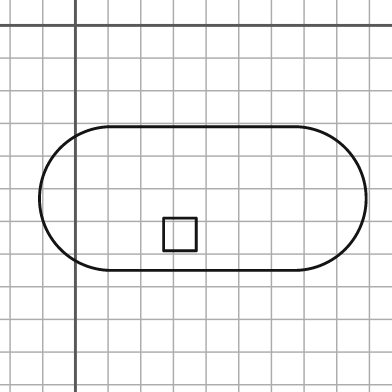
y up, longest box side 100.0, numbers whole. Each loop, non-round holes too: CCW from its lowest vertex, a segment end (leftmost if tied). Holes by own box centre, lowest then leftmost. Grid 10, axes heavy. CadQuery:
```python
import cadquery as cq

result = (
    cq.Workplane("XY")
    .moveTo(11.0, -75.0)
    .lineTo(67.0, -75.0)
    .threePointArc((89.0, -53.0), (67.0, -31.0))
    .lineTo(11.0, -31.0)
    .threePointArc((-11.0, -53.0), (11.0, -75.0))
    .close()
    .moveTo(27.0, -69.0)
    .lineTo(37.0, -69.0)
    .lineTo(37.0, -59.0)
    .lineTo(27.0, -59.0)
    .close()
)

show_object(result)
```